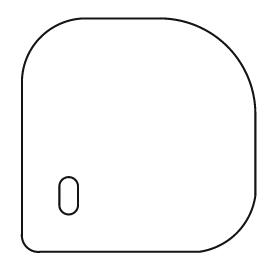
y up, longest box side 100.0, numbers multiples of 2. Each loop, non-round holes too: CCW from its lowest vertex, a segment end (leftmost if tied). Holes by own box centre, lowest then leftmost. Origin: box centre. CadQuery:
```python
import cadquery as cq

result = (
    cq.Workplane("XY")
    .moveTo(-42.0, -50.0)
    .lineTo(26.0, -50.0)
    .threePointArc((42.0, -42.0), (50.0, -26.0))
    .lineTo(50.0, 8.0)
    .threePointArc((38.0, 38.0), (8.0, 50.0))
    .lineTo(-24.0, 50.0)
    .threePointArc((-42.0, 42.0), (-50.0, 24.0))
    .lineTo(-50.0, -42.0)
    .threePointArc((-48.0, -48.0), (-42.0, -50.0))
    .close()
    .moveTo(-34.0, -30.0)
    .threePointArc((-30.0, -34.0), (-26.0, -30.0))
    .lineTo(-26.0, -22.0)
    .threePointArc((-30.0, -18.0), (-34.0, -22.0))
    .close()
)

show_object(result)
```